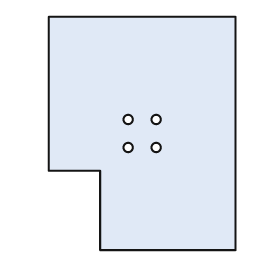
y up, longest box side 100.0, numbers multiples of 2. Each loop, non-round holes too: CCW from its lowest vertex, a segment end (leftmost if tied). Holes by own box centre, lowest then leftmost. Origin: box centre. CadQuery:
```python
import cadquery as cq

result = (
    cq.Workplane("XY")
    .moveTo(-18.0, -50.0)
    .lineTo(40.0, -50.0)
    .lineTo(40.0, 50.0)
    .lineTo(-40.0, 50.0)
    .lineTo(-40.0, -16.0)
    .lineTo(-18.0, -16.0)
    .close()
    .moveTo(-6.0, -6.0)
    .circle(2.0)
    .moveTo(6.0, -6.0)
    .circle(2.0)
    .moveTo(-6.0, 6.0)
    .circle(2.0)
    .moveTo(6.0, 6.0)
    .circle(2.0)
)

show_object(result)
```